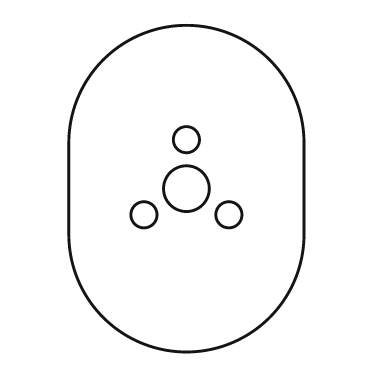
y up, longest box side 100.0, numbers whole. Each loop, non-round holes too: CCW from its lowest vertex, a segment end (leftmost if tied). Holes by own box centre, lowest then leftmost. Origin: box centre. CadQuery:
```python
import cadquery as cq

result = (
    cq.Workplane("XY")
    .moveTo(-36.0, -14.0)
    .threePointArc((0.0, -50.0), (36.0, -14.0))
    .lineTo(36.0, 14.0)
    .threePointArc((0.0, 50.0), (-36.0, 14.0))
    .close()
    .moveTo(-13.0, -8.0)
    .circle(4.0)
    .moveTo(13.0, -8.0)
    .circle(4.0)
    .moveTo(0.0, 0.0)
    .circle(7.0)
    .moveTo(0.0, 15.0)
    .circle(4.0)
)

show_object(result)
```